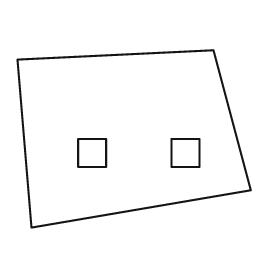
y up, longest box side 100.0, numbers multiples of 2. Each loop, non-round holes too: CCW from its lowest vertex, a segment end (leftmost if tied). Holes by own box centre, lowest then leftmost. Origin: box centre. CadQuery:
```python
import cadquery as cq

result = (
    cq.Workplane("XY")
    .moveTo(-44.0, -38.0)
    .lineTo(50.0, -22.0)
    .lineTo(34.0, 38.0)
    .lineTo(-50.0, 34.0)
    .close()
    .moveTo(-24.0, -12.0)
    .lineTo(-12.0, -12.0)
    .lineTo(-12.0, 0.0)
    .lineTo(-24.0, 0.0)
    .close()
    .moveTo(16.0, -12.0)
    .lineTo(28.0, -12.0)
    .lineTo(28.0, 0.0)
    .lineTo(16.0, 0.0)
    .close()
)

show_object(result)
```